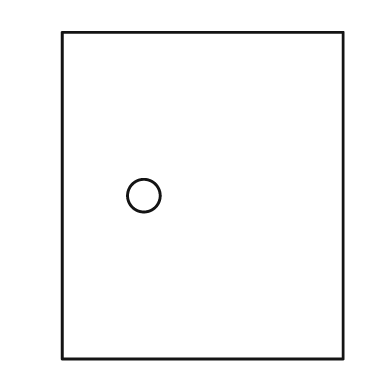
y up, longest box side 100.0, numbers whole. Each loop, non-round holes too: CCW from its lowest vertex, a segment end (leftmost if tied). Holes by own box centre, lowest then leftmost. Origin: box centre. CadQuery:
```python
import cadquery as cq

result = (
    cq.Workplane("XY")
    .moveTo(-43.0, -50.0)
    .lineTo(43.0, -50.0)
    .lineTo(43.0, 50.0)
    .lineTo(-43.0, 50.0)
    .close()
    .moveTo(-18.0, 0.0)
    .circle(5.0)
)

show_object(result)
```